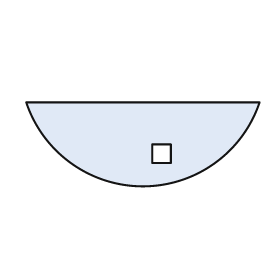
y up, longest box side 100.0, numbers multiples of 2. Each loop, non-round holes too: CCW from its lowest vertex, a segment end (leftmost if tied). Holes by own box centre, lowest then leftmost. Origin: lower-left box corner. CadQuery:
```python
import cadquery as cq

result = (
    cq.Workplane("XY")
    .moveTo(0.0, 36.0)
    .threePointArc((50.0, 0.0), (100.0, 36.0))
    .close()
    .moveTo(54.0, 10.0)
    .lineTo(62.0, 10.0)
    .lineTo(62.0, 18.0)
    .lineTo(54.0, 18.0)
    .close()
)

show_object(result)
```